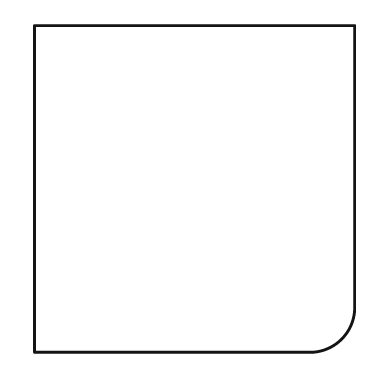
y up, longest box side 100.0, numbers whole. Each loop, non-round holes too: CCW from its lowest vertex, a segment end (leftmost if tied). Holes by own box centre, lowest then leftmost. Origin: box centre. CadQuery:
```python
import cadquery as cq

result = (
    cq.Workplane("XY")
    .moveTo(-49.0, -50.0)
    .lineTo(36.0, -50.0)
    .threePointArc((45.0, -46.0), (49.0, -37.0))
    .lineTo(49.0, 50.0)
    .lineTo(-49.0, 50.0)
    .close()
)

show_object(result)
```